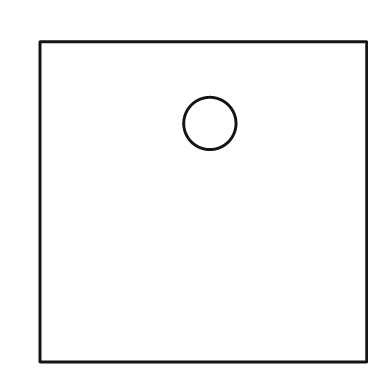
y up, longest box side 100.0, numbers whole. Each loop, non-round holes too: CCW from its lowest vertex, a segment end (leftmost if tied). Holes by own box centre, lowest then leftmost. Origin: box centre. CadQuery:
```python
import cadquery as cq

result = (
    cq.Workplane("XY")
    .moveTo(-50.0, -49.0)
    .lineTo(50.0, -49.0)
    .lineTo(50.0, 49.0)
    .lineTo(-50.0, 49.0)
    .close()
    .moveTo(2.0, 24.0)
    .circle(8.0)
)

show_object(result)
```